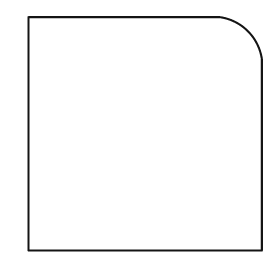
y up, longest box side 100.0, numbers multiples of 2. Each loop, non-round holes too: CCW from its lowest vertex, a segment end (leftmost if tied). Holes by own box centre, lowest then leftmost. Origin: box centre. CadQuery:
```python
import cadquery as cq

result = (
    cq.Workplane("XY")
    .moveTo(-50.0, -50.0)
    .lineTo(50.0, -50.0)
    .lineTo(50.0, 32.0)
    .threePointArc((44.0, 44.0), (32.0, 50.0))
    .lineTo(-50.0, 50.0)
    .close()
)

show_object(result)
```